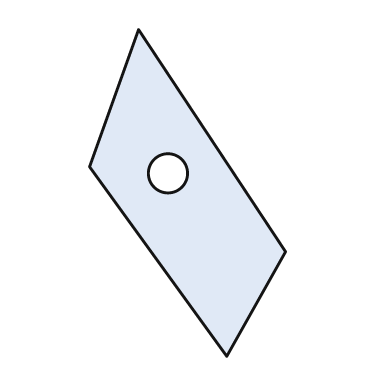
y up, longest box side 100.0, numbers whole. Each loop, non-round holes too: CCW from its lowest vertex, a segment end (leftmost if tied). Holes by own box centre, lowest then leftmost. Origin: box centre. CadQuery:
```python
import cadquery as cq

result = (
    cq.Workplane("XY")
    .moveTo(12.0, -50.0)
    .lineTo(30.0, -18.0)
    .lineTo(-15.0, 50.0)
    .lineTo(-30.0, 8.0)
    .close()
    .moveTo(-6.0, 6.0)
    .circle(6.0)
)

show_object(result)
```